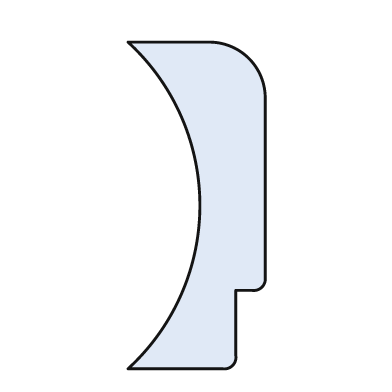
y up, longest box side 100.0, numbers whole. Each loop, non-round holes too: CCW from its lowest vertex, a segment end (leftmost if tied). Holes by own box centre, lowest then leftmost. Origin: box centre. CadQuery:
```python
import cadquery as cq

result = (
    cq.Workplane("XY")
    .moveTo(-21.0, -50.0)
    .lineTo(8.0, -50.0)
    .threePointArc((11.0, -49.0), (12.0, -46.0))
    .lineTo(12.0, -26.0)
    .lineTo(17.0, -26.0)
    .threePointArc((20.0, -25.0), (21.0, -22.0))
    .lineTo(21.0, 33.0)
    .threePointArc((16.0, 45.0), (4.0, 50.0))
    .lineTo(-21.0, 50.0)
    .threePointArc((1.0, 0.0), (-21.0, -50.0))
    .close()
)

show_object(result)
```